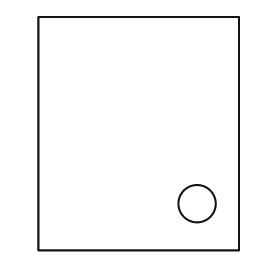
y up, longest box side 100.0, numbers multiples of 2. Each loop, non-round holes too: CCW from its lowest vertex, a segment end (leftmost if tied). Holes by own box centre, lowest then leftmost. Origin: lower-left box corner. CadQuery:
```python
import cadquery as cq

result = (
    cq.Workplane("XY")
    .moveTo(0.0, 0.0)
    .lineTo(86.0, 0.0)
    .lineTo(86.0, 100.0)
    .lineTo(0.0, 100.0)
    .close()
    .moveTo(68.0, 20.0)
    .circle(8.0)
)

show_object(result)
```